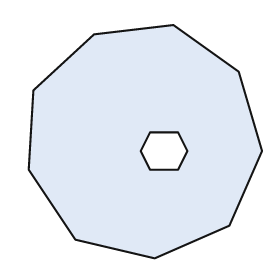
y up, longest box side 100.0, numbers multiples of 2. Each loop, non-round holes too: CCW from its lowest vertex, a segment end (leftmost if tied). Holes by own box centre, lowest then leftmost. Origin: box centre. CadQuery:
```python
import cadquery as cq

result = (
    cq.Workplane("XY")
    .moveTo(4.0, -50.0)
    .lineTo(36.0, -36.0)
    .lineTo(50.0, -4.0)
    .lineTo(40.0, 30.0)
    .lineTo(12.0, 50.0)
    .lineTo(-22.0, 46.0)
    .lineTo(-48.0, 22.0)
    .lineTo(-50.0, -12.0)
    .lineTo(-30.0, -42.0)
    .close()
    .moveTo(2.0, -12.0)
    .lineTo(14.0, -12.0)
    .lineTo(18.0, -4.0)
    .lineTo(14.0, 4.0)
    .lineTo(2.0, 4.0)
    .lineTo(-2.0, -4.0)
    .close()
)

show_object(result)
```